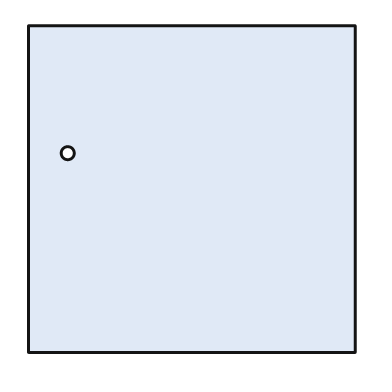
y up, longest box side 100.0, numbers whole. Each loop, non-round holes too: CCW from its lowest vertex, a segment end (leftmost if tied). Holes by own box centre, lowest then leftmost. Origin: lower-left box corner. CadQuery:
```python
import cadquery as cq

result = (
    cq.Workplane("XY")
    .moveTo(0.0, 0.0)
    .lineTo(100.0, 0.0)
    .lineTo(100.0, 100.0)
    .lineTo(0.0, 100.0)
    .close()
    .moveTo(12.0, 61.0)
    .circle(2.0)
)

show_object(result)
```